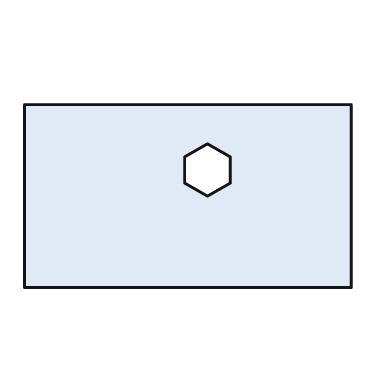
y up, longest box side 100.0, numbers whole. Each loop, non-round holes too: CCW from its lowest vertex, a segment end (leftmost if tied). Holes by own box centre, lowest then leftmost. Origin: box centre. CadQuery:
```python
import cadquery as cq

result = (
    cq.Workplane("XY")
    .moveTo(-50.0, -28.0)
    .lineTo(50.0, -28.0)
    .lineTo(50.0, 28.0)
    .lineTo(-50.0, 28.0)
    .close()
    .moveTo(6.0, 0.0)
    .lineTo(13.0, 4.0)
    .lineTo(13.0, 12.0)
    .lineTo(6.0, 16.0)
    .lineTo(-1.0, 12.0)
    .lineTo(-1.0, 4.0)
    .close()
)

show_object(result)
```